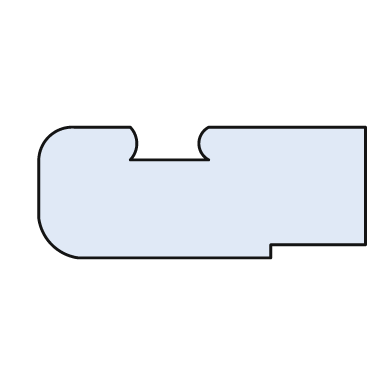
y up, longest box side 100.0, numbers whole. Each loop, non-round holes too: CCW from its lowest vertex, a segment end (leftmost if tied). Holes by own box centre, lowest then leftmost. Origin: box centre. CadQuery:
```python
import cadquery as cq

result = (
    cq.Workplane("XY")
    .moveTo(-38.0, -20.0)
    .lineTo(21.0, -20.0)
    .lineTo(21.0, -16.0)
    .lineTo(50.0, -16.0)
    .lineTo(50.0, 20.0)
    .lineTo(2.0, 20.0)
    .threePointArc((-1.0, 15.0), (2.0, 10.0))
    .lineTo(-22.0, 10.0)
    .threePointArc((-20.0, 15.0), (-22.0, 20.0))
    .lineTo(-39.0, 20.0)
    .threePointArc((-47.0, 17.0), (-50.0, 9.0))
    .lineTo(-50.0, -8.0)
    .threePointArc((-46.0, -16.0), (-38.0, -20.0))
    .close()
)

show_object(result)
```